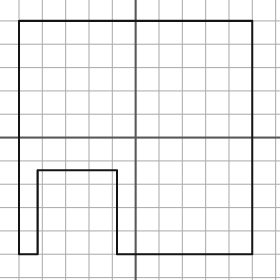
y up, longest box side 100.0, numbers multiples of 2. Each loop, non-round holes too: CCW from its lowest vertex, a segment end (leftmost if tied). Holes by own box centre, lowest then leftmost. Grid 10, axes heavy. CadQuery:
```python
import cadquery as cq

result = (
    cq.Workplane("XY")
    .moveTo(-50.0, -50.0)
    .lineTo(-42.0, -50.0)
    .lineTo(-42.0, -14.0)
    .lineTo(-8.0, -14.0)
    .lineTo(-8.0, -50.0)
    .lineTo(50.0, -50.0)
    .lineTo(50.0, 50.0)
    .lineTo(-50.0, 50.0)
    .close()
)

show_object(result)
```